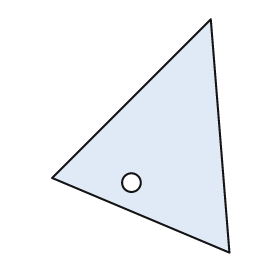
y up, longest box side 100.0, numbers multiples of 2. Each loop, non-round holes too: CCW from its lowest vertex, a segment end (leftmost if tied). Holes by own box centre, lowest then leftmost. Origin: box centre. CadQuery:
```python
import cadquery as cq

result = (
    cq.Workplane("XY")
    .moveTo(38.0, -50.0)
    .lineTo(30.0, 50.0)
    .lineTo(-38.0, -18.0)
    .close()
    .moveTo(-4.0, -20.0)
    .circle(4.0)
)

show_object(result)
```